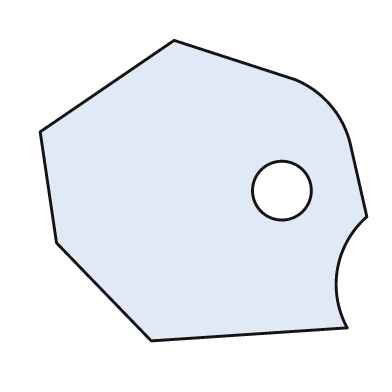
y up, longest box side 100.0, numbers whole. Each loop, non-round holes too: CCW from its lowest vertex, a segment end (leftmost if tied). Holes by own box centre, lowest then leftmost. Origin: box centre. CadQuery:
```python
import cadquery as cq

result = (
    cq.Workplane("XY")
    .moveTo(-16.0, -46.0)
    .lineTo(44.0, -42.0)
    .threePointArc((41.0, -24.0), (50.0, -8.0))
    .lineTo(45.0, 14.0)
    .threePointArc((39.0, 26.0), (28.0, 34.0))
    .lineTo(-9.0, 46.0)
    .lineTo(-50.0, 18.0)
    .lineTo(-45.0, -16.0)
    .close()
    .moveTo(24.0, 0.0)
    .circle(9.0)
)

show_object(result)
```